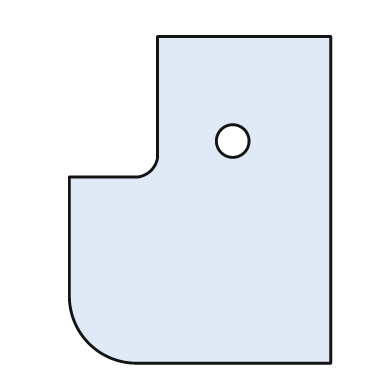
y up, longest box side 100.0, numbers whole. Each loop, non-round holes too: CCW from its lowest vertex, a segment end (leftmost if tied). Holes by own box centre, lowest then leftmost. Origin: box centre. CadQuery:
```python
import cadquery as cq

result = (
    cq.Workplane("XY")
    .moveTo(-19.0, -50.0)
    .lineTo(40.0, -50.0)
    .lineTo(40.0, 50.0)
    .lineTo(-13.0, 50.0)
    .lineTo(-13.0, 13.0)
    .threePointArc((-15.0, 9.0), (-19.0, 7.0))
    .lineTo(-40.0, 7.0)
    .lineTo(-40.0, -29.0)
    .threePointArc((-34.0, -44.0), (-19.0, -50.0))
    .close()
    .moveTo(10.0, 18.0)
    .circle(5.0)
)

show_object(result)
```